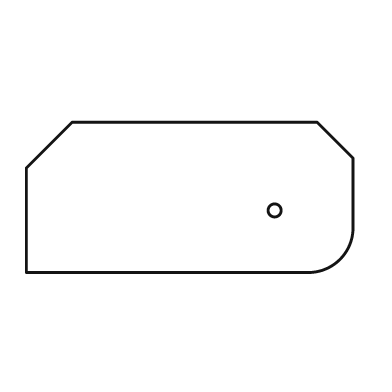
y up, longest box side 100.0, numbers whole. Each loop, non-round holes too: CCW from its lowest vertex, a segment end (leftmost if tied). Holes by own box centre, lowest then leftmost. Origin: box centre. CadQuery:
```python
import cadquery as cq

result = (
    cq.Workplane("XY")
    .moveTo(-50.0, -23.0)
    .lineTo(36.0, -23.0)
    .threePointArc((46.0, -19.0), (50.0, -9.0))
    .lineTo(50.0, 12.0)
    .lineTo(39.0, 23.0)
    .lineTo(-36.0, 23.0)
    .lineTo(-50.0, 9.0)
    .close()
    .moveTo(26.0, -4.0)
    .circle(2.0)
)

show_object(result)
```